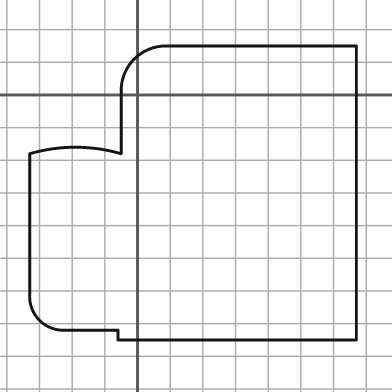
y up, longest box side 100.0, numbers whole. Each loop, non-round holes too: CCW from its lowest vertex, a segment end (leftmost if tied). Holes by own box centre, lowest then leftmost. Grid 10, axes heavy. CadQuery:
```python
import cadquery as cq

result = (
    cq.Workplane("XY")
    .moveTo(-6.0, -75.0)
    .lineTo(67.0, -75.0)
    .lineTo(67.0, 15.0)
    .lineTo(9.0, 15.0)
    .threePointArc((-1.0, 11.0), (-5.0, 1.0))
    .lineTo(-5.0, -18.0)
    .threePointArc((-19.0, -16.0), (-33.0, -18.0))
    .lineTo(-33.0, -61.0)
    .threePointArc((-30.0, -69.0), (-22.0, -72.0))
    .lineTo(-6.0, -72.0)
    .close()
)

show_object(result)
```